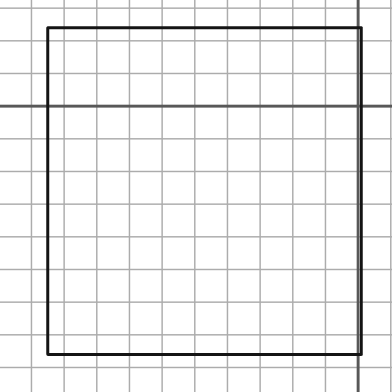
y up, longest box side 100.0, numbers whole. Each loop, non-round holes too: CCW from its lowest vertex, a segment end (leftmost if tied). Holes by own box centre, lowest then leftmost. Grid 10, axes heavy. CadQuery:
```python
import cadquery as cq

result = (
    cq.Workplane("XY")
    .moveTo(-95.0, -76.0)
    .lineTo(1.0, -76.0)
    .lineTo(1.0, 24.0)
    .lineTo(-95.0, 24.0)
    .close()
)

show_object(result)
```